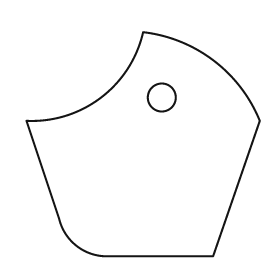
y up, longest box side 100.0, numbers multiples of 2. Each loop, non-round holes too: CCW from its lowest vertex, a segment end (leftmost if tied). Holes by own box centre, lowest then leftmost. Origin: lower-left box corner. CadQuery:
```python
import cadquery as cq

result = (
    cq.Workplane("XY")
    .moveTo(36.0, 0.0)
    .lineTo(80.0, 0.0)
    .lineTo(100.0, 58.0)
    .threePointArc((80.0, 84.0), (50.0, 96.0))
    .threePointArc((32.0, 68.0), (0.0, 58.0))
    .lineTo(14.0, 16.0)
    .threePointArc((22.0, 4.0), (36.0, 0.0))
    .close()
    .moveTo(58.0, 68.0)
    .circle(6.0)
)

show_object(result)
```